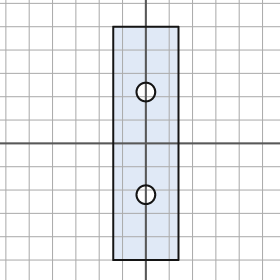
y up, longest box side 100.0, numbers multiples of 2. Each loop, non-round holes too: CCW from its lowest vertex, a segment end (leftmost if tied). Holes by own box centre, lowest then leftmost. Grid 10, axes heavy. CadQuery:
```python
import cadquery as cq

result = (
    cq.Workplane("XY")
    .moveTo(-14.0, -50.0)
    .lineTo(14.0, -50.0)
    .lineTo(14.0, 50.0)
    .lineTo(-14.0, 50.0)
    .close()
    .moveTo(0.0, -22.0)
    .circle(4.0)
    .moveTo(0.0, 22.0)
    .circle(4.0)
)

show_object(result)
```